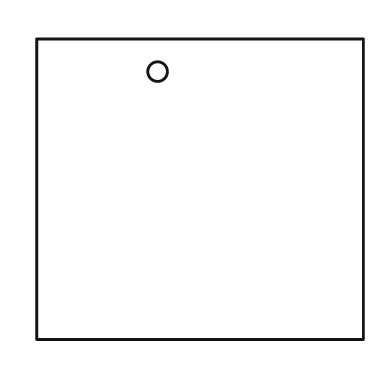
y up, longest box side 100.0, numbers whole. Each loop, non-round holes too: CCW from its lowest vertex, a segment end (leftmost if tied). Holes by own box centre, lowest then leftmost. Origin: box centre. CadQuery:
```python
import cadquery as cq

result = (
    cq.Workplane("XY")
    .moveTo(-50.0, -46.0)
    .lineTo(50.0, -46.0)
    .lineTo(50.0, 46.0)
    .lineTo(-50.0, 46.0)
    .close()
    .moveTo(-13.0, 36.0)
    .circle(3.0)
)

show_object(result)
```